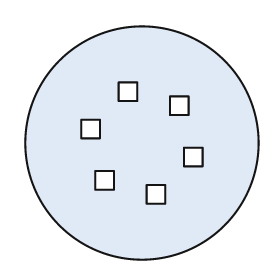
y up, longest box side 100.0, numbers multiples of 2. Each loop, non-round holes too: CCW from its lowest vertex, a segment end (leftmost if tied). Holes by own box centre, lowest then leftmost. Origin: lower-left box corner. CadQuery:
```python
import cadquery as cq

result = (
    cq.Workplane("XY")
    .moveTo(50.0, 50.0)
    .circle(50.0)
    .moveTo(52.0, 24.0)
    .lineTo(60.0, 24.0)
    .lineTo(60.0, 32.0)
    .lineTo(52.0, 32.0)
    .close()
    .moveTo(30.0, 30.0)
    .lineTo(38.0, 30.0)
    .lineTo(38.0, 38.0)
    .lineTo(30.0, 38.0)
    .close()
    .moveTo(68.0, 40.0)
    .lineTo(76.0, 40.0)
    .lineTo(76.0, 48.0)
    .lineTo(68.0, 48.0)
    .close()
    .moveTo(24.0, 52.0)
    .lineTo(32.0, 52.0)
    .lineTo(32.0, 60.0)
    .lineTo(24.0, 60.0)
    .close()
    .moveTo(62.0, 62.0)
    .lineTo(70.0, 62.0)
    .lineTo(70.0, 70.0)
    .lineTo(62.0, 70.0)
    .close()
    .moveTo(40.0, 68.0)
    .lineTo(48.0, 68.0)
    .lineTo(48.0, 76.0)
    .lineTo(40.0, 76.0)
    .close()
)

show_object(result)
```